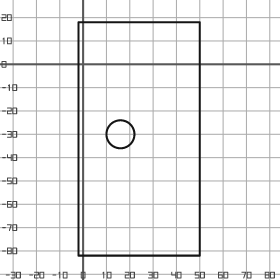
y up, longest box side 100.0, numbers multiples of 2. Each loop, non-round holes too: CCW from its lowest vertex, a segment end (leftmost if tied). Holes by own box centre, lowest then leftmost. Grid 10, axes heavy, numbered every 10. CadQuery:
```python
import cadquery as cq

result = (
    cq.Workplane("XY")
    .moveTo(-2.0, -82.0)
    .lineTo(50.0, -82.0)
    .lineTo(50.0, 18.0)
    .lineTo(-2.0, 18.0)
    .close()
    .moveTo(16.0, -30.0)
    .circle(6.0)
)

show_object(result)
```